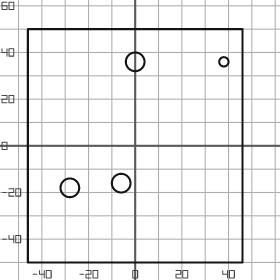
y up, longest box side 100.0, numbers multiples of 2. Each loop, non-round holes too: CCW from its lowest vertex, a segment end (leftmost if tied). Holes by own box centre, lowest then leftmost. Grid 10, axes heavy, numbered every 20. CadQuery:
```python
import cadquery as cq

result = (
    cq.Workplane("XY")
    .moveTo(-46.0, -50.0)
    .lineTo(46.0, -50.0)
    .lineTo(46.0, 50.0)
    .lineTo(-46.0, 50.0)
    .close()
    .moveTo(-28.0, -18.0)
    .circle(4.0)
    .moveTo(-6.0, -16.0)
    .circle(4.0)
    .moveTo(0.0, 36.0)
    .circle(4.0)
    .moveTo(38.0, 36.0)
    .circle(2.0)
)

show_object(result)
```